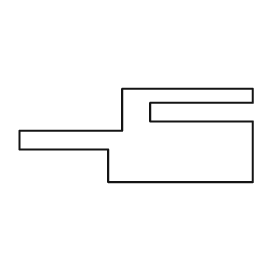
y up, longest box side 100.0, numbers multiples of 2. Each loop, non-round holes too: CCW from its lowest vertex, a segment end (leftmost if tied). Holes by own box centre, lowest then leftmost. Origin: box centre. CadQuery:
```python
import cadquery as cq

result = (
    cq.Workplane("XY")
    .moveTo(-12.0, -20.0)
    .lineTo(50.0, -20.0)
    .lineTo(50.0, 6.0)
    .lineTo(6.0, 6.0)
    .lineTo(6.0, 14.0)
    .lineTo(50.0, 14.0)
    .lineTo(50.0, 20.0)
    .lineTo(-6.0, 20.0)
    .lineTo(-6.0, 2.0)
    .lineTo(-50.0, 2.0)
    .lineTo(-50.0, -6.0)
    .lineTo(-12.0, -6.0)
    .close()
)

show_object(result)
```